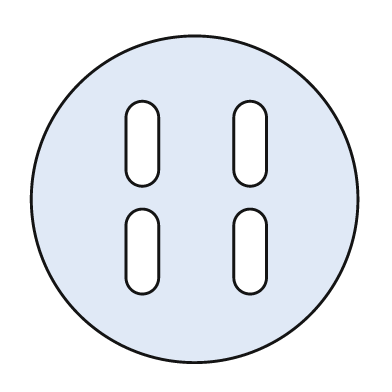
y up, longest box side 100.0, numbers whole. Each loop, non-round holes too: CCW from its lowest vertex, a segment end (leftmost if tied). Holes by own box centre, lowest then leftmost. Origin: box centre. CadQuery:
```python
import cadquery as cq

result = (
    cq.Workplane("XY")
    .moveTo(0.0, 0.0)
    .circle(50.0)
    .moveTo(-21.0, -24.0)
    .threePointArc((-16.0, -29.0), (-11.0, -24.0))
    .lineTo(-11.0, -8.0)
    .threePointArc((-16.0, -3.0), (-21.0, -8.0))
    .close()
    .moveTo(12.0, -24.0)
    .threePointArc((17.0, -29.0), (22.0, -24.0))
    .lineTo(22.0, -8.0)
    .threePointArc((17.0, -3.0), (12.0, -8.0))
    .close()
    .moveTo(-21.0, 9.0)
    .threePointArc((-16.0, 4.0), (-11.0, 9.0))
    .lineTo(-11.0, 25.0)
    .threePointArc((-16.0, 30.0), (-21.0, 25.0))
    .close()
    .moveTo(12.0, 9.0)
    .threePointArc((17.0, 4.0), (22.0, 9.0))
    .lineTo(22.0, 25.0)
    .threePointArc((17.0, 30.0), (12.0, 25.0))
    .close()
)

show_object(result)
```